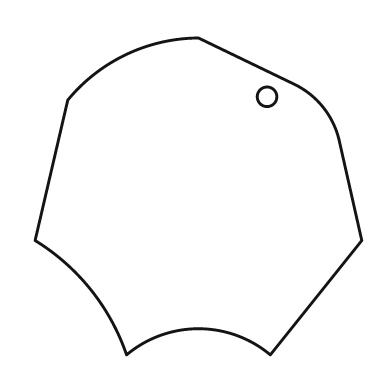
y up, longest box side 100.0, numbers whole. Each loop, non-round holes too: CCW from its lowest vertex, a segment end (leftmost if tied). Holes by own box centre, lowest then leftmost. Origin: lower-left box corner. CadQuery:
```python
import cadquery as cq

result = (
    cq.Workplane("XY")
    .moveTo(28.0, 0.0)
    .threePointArc((50.0, 8.0), (72.0, 0.0))
    .lineTo(100.0, 35.0)
    .lineTo(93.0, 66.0)
    .threePointArc((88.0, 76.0), (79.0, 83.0))
    .lineTo(50.0, 97.0)
    .threePointArc((28.0, 92.0), (10.0, 78.0))
    .lineTo(0.0, 35.0)
    .threePointArc((17.0, 20.0), (28.0, 0.0))
    .close()
    .moveTo(71.0, 79.0)
    .circle(3.0)
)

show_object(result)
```